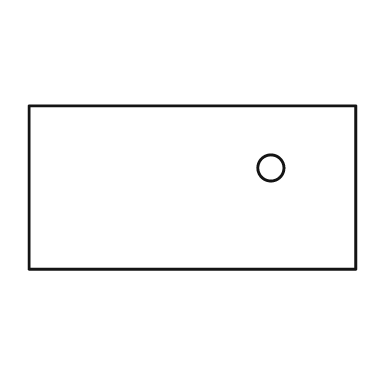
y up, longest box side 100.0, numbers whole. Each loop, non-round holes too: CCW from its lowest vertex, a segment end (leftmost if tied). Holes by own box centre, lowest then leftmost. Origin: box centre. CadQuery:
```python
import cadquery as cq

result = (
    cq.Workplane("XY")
    .moveTo(-50.0, -25.0)
    .lineTo(50.0, -25.0)
    .lineTo(50.0, 25.0)
    .lineTo(-50.0, 25.0)
    .close()
    .moveTo(24.0, 6.0)
    .circle(4.0)
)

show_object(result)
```